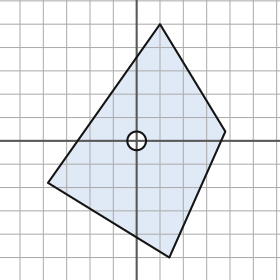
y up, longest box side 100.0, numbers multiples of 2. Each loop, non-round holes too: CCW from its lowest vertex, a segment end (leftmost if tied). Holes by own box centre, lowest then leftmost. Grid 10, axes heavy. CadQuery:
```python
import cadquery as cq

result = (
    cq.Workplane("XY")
    .moveTo(14.0, -50.0)
    .lineTo(38.0, 4.0)
    .lineTo(10.0, 50.0)
    .lineTo(-38.0, -18.0)
    .close()
    .moveTo(0.0, 0.0)
    .circle(4.0)
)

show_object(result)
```